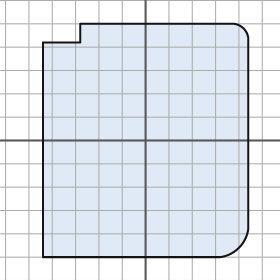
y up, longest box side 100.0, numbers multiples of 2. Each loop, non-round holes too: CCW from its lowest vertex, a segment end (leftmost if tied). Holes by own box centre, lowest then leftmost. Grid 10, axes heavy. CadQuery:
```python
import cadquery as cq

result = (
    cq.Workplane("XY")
    .moveTo(-44.0, -50.0)
    .lineTo(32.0, -50.0)
    .threePointArc((40.0, -46.0), (44.0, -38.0))
    .lineTo(44.0, 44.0)
    .threePointArc((42.0, 48.0), (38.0, 50.0))
    .lineTo(-28.0, 50.0)
    .lineTo(-28.0, 42.0)
    .lineTo(-44.0, 42.0)
    .close()
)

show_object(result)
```